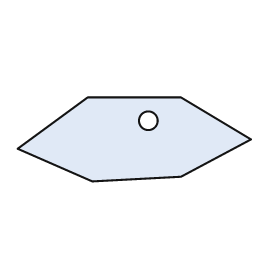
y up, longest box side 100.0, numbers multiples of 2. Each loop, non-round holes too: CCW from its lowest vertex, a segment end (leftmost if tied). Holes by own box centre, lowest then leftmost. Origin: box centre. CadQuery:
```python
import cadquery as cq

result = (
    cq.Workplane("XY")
    .moveTo(-18.0, -18.0)
    .lineTo(20.0, -16.0)
    .lineTo(50.0, 0.0)
    .lineTo(20.0, 18.0)
    .lineTo(-20.0, 18.0)
    .lineTo(-50.0, -4.0)
    .close()
    .moveTo(6.0, 8.0)
    .circle(4.0)
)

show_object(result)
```